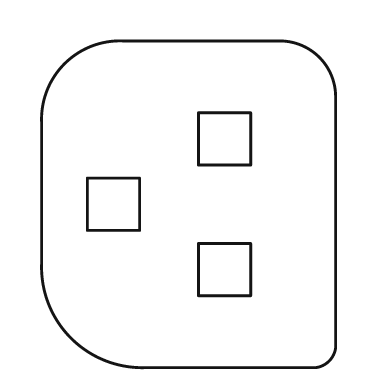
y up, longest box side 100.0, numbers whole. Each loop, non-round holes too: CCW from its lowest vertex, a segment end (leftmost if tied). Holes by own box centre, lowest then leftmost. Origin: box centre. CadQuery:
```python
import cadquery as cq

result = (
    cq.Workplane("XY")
    .moveTo(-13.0, -50.0)
    .lineTo(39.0, -50.0)
    .threePointArc((43.0, -48.0), (45.0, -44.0))
    .lineTo(45.0, 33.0)
    .threePointArc((40.0, 45.0), (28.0, 50.0))
    .lineTo(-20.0, 50.0)
    .threePointArc((-38.0, 43.0), (-45.0, 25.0))
    .lineTo(-45.0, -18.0)
    .threePointArc((-36.0, -41.0), (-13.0, -50.0))
    .close()
    .moveTo(3.0, -28.0)
    .lineTo(19.0, -28.0)
    .lineTo(19.0, -12.0)
    .lineTo(3.0, -12.0)
    .close()
    .moveTo(-31.0, -8.0)
    .lineTo(-15.0, -8.0)
    .lineTo(-15.0, 8.0)
    .lineTo(-31.0, 8.0)
    .close()
    .moveTo(3.0, 12.0)
    .lineTo(19.0, 12.0)
    .lineTo(19.0, 28.0)
    .lineTo(3.0, 28.0)
    .close()
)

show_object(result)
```